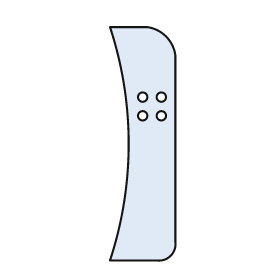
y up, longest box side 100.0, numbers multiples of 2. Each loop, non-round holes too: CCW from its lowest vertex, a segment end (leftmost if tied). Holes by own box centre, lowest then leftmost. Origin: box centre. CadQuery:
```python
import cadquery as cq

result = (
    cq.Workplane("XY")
    .moveTo(-14.0, -50.0)
    .lineTo(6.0, -50.0)
    .threePointArc((12.0, -48.0), (14.0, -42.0))
    .lineTo(14.0, 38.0)
    .threePointArc((10.0, 46.0), (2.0, 50.0))
    .lineTo(-14.0, 50.0)
    .threePointArc((-6.0, 0.0), (-14.0, -50.0))
    .close()
    .moveTo(0.0, 12.0)
    .circle(2.0)
    .moveTo(8.0, 12.0)
    .circle(2.0)
    .moveTo(0.0, 20.0)
    .circle(2.0)
    .moveTo(8.0, 20.0)
    .circle(2.0)
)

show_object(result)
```